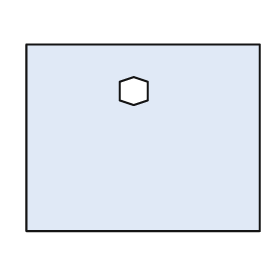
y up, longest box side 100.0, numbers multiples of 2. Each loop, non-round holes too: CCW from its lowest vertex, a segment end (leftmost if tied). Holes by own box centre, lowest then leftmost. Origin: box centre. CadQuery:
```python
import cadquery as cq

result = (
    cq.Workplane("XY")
    .moveTo(-50.0, -40.0)
    .lineTo(50.0, -40.0)
    .lineTo(50.0, 40.0)
    .lineTo(-50.0, 40.0)
    .close()
    .moveTo(-4.0, 14.0)
    .lineTo(2.0, 16.0)
    .lineTo(2.0, 24.0)
    .lineTo(-4.0, 26.0)
    .lineTo(-10.0, 24.0)
    .lineTo(-10.0, 16.0)
    .close()
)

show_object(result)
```